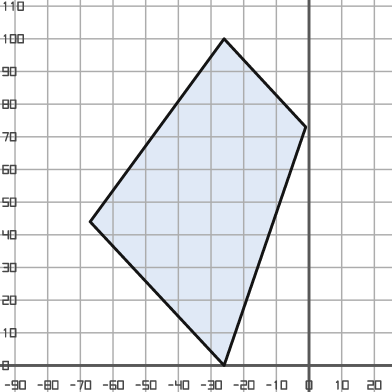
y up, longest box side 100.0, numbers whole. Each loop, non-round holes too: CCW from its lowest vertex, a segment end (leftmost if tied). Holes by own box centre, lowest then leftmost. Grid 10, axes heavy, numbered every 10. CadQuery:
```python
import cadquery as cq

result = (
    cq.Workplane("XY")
    .moveTo(-26.0, 0.0)
    .lineTo(-1.0, 73.0)
    .lineTo(-26.0, 100.0)
    .lineTo(-67.0, 44.0)
    .close()
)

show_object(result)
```